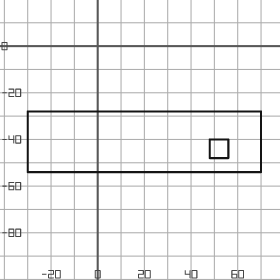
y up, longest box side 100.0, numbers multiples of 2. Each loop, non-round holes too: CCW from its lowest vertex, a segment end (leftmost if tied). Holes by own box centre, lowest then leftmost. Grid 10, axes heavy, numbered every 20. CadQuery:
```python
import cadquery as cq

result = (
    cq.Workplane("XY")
    .moveTo(-30.0, -54.0)
    .lineTo(70.0, -54.0)
    .lineTo(70.0, -28.0)
    .lineTo(-30.0, -28.0)
    .close()
    .moveTo(48.0, -48.0)
    .lineTo(56.0, -48.0)
    .lineTo(56.0, -40.0)
    .lineTo(48.0, -40.0)
    .close()
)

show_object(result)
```